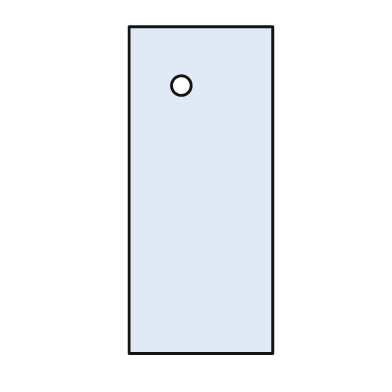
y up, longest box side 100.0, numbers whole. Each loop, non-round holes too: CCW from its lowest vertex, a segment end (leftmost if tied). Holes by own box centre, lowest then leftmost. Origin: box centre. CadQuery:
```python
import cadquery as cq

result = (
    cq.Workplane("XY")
    .moveTo(-22.0, -50.0)
    .lineTo(22.0, -50.0)
    .lineTo(22.0, 50.0)
    .lineTo(-22.0, 50.0)
    .close()
    .moveTo(-6.0, 32.0)
    .circle(3.0)
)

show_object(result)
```